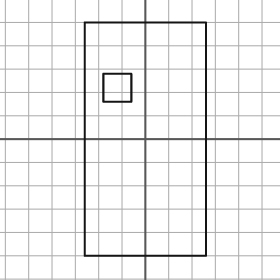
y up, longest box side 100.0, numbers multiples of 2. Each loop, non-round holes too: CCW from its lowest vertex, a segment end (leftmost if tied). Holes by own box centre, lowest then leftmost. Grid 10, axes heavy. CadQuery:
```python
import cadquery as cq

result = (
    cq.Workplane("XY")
    .moveTo(-26.0, -50.0)
    .lineTo(26.0, -50.0)
    .lineTo(26.0, 50.0)
    .lineTo(-26.0, 50.0)
    .close()
    .moveTo(-18.0, 16.0)
    .lineTo(-6.0, 16.0)
    .lineTo(-6.0, 28.0)
    .lineTo(-18.0, 28.0)
    .close()
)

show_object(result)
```